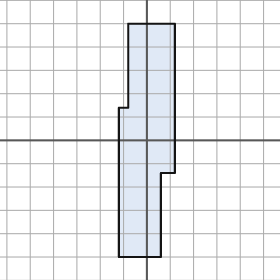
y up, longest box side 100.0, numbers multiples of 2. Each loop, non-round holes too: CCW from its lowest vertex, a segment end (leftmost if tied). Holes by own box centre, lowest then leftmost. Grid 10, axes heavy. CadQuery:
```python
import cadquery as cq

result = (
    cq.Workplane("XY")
    .moveTo(-12.0, -50.0)
    .lineTo(6.0, -50.0)
    .lineTo(6.0, -14.0)
    .lineTo(12.0, -14.0)
    .lineTo(12.0, 50.0)
    .lineTo(-8.0, 50.0)
    .lineTo(-8.0, 14.0)
    .lineTo(-12.0, 14.0)
    .close()
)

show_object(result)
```